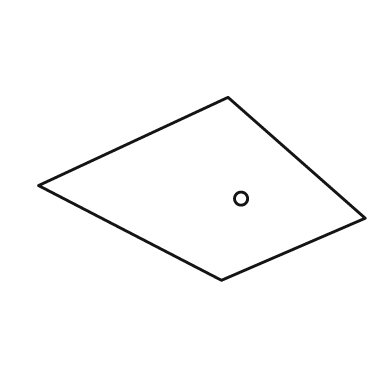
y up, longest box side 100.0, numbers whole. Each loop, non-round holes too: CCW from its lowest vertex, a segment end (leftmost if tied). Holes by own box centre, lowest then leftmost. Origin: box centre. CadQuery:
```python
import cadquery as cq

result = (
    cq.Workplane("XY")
    .moveTo(6.0, -28.0)
    .lineTo(50.0, -9.0)
    .lineTo(8.0, 28.0)
    .lineTo(-50.0, 1.0)
    .close()
    .moveTo(12.0, -3.0)
    .circle(2.0)
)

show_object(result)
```